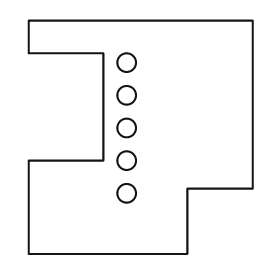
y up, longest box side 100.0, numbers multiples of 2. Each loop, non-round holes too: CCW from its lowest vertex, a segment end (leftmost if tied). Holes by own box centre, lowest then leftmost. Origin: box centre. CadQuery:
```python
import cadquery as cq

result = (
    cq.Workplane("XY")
    .moveTo(-48.0, -50.0)
    .lineTo(20.0, -50.0)
    .lineTo(20.0, -22.0)
    .lineTo(48.0, -22.0)
    .lineTo(48.0, 50.0)
    .lineTo(-48.0, 50.0)
    .lineTo(-48.0, 36.0)
    .lineTo(-16.0, 36.0)
    .lineTo(-16.0, -10.0)
    .lineTo(-48.0, -10.0)
    .close()
    .moveTo(-6.0, -24.0)
    .circle(4.0)
    .moveTo(-6.0, -10.0)
    .circle(4.0)
    .moveTo(-6.0, 4.0)
    .circle(4.0)
    .moveTo(-6.0, 18.0)
    .circle(4.0)
    .moveTo(-6.0, 32.0)
    .circle(4.0)
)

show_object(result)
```